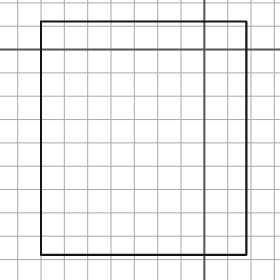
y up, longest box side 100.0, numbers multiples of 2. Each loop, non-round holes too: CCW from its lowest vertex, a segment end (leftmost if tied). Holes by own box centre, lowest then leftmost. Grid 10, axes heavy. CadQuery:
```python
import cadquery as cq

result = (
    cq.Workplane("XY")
    .moveTo(-70.0, -88.0)
    .lineTo(18.0, -88.0)
    .lineTo(18.0, 12.0)
    .lineTo(-70.0, 12.0)
    .close()
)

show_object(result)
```